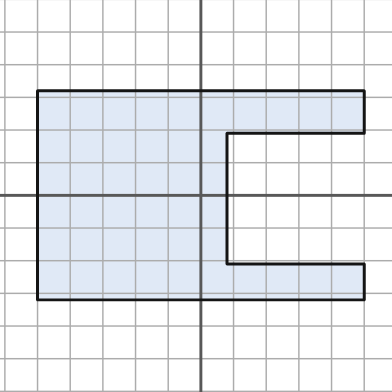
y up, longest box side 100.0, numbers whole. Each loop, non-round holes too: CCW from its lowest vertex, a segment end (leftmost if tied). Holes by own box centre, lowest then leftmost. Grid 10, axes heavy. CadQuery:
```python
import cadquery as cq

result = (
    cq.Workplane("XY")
    .moveTo(-50.0, -32.0)
    .lineTo(50.0, -32.0)
    .lineTo(50.0, -21.0)
    .lineTo(8.0, -21.0)
    .lineTo(8.0, 19.0)
    .lineTo(50.0, 19.0)
    .lineTo(50.0, 32.0)
    .lineTo(-50.0, 32.0)
    .close()
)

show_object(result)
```